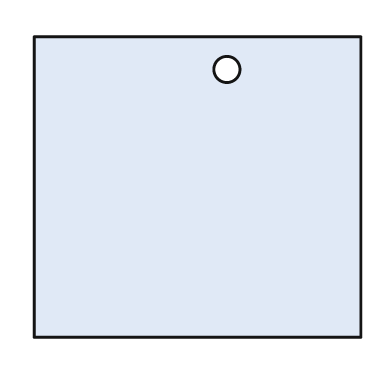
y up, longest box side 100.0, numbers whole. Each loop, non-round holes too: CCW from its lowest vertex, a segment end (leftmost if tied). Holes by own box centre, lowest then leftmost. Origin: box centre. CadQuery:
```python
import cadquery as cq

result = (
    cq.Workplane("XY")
    .moveTo(-50.0, -46.0)
    .lineTo(50.0, -46.0)
    .lineTo(50.0, 46.0)
    .lineTo(-50.0, 46.0)
    .close()
    .moveTo(9.0, 36.0)
    .circle(4.0)
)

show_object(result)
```